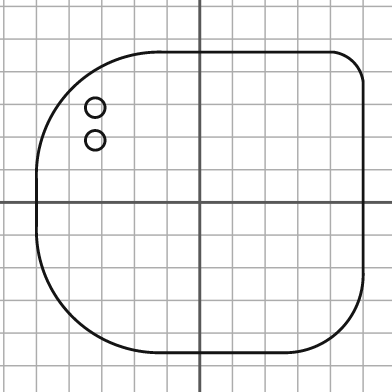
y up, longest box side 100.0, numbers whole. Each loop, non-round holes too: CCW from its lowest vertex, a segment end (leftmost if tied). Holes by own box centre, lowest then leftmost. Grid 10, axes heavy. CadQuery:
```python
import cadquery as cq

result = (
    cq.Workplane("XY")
    .moveTo(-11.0, -46.0)
    .lineTo(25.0, -46.0)
    .threePointArc((43.0, -39.0), (50.0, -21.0))
    .lineTo(50.0, 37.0)
    .threePointArc((47.0, 43.0), (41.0, 46.0))
    .lineTo(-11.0, 46.0)
    .threePointArc((-39.0, 35.0), (-50.0, 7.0))
    .lineTo(-50.0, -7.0)
    .threePointArc((-39.0, -35.0), (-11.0, -46.0))
    .close()
    .moveTo(-32.0, 19.0)
    .circle(3.0)
    .moveTo(-32.0, 29.0)
    .circle(3.0)
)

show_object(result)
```